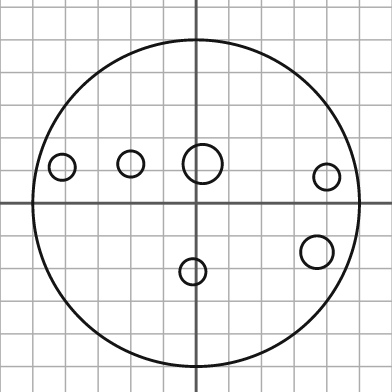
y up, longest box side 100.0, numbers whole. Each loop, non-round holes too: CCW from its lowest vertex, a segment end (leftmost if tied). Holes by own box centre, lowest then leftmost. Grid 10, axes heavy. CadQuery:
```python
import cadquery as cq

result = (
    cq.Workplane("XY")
    .moveTo(0.0, 0.0)
    .circle(50.0)
    .moveTo(-1.0, -21.0)
    .circle(4.0)
    .moveTo(37.0, -15.0)
    .circle(5.0)
    .moveTo(40.0, 8.0)
    .circle(4.0)
    .moveTo(-41.0, 11.0)
    .circle(4.0)
    .moveTo(-20.0, 12.0)
    .circle(4.0)
    .moveTo(2.0, 12.0)
    .circle(6.0)
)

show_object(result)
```